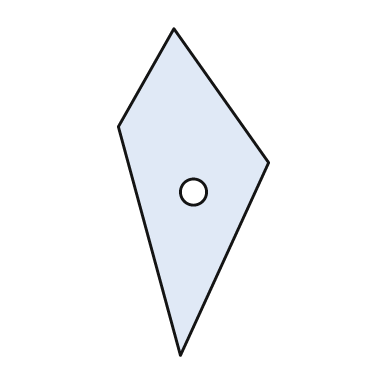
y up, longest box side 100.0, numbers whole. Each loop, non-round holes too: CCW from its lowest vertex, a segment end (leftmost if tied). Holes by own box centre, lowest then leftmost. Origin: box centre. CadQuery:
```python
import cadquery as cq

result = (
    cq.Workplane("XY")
    .moveTo(-4.0, -50.0)
    .lineTo(23.0, 9.0)
    .lineTo(-6.0, 50.0)
    .lineTo(-23.0, 20.0)
    .close()
    .moveTo(0.0, 0.0)
    .circle(4.0)
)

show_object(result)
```